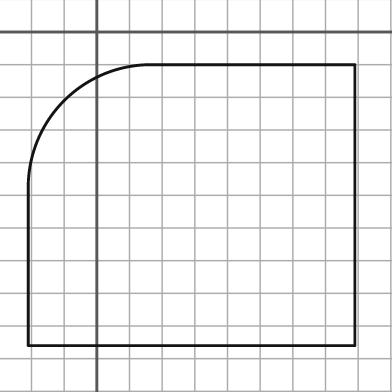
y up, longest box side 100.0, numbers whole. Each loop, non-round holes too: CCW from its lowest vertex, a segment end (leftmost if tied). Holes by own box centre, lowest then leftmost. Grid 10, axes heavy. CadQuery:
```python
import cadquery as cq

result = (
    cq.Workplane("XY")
    .moveTo(-21.0, -96.0)
    .lineTo(79.0, -96.0)
    .lineTo(79.0, -10.0)
    .lineTo(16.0, -10.0)
    .threePointArc((-10.0, -21.0), (-21.0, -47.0))
    .close()
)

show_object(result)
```